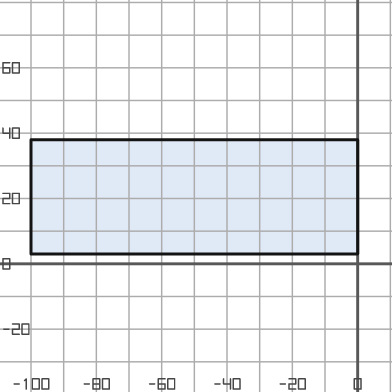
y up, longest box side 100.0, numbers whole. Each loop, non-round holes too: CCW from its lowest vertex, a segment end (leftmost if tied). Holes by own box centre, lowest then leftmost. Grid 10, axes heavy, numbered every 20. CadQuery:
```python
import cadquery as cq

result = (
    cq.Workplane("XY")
    .moveTo(-100.0, 3.0)
    .lineTo(0.0, 3.0)
    .lineTo(0.0, 38.0)
    .lineTo(-100.0, 38.0)
    .close()
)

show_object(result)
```